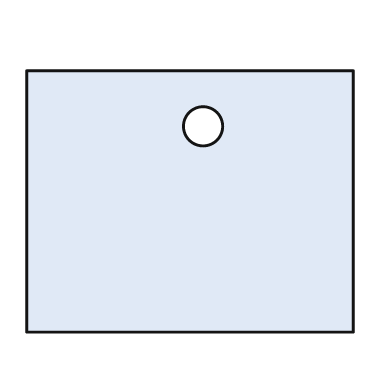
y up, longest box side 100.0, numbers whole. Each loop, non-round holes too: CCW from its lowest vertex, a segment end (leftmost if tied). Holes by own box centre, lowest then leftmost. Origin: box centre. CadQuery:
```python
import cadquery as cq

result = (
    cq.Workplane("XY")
    .moveTo(-50.0, -40.0)
    .lineTo(50.0, -40.0)
    .lineTo(50.0, 40.0)
    .lineTo(-50.0, 40.0)
    .close()
    .moveTo(4.0, 23.0)
    .circle(6.0)
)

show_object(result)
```